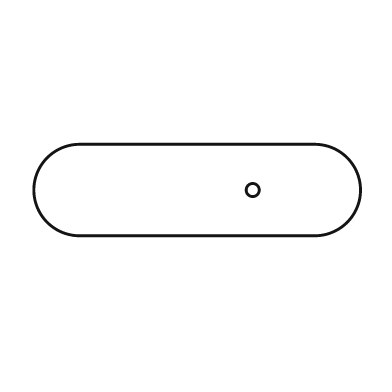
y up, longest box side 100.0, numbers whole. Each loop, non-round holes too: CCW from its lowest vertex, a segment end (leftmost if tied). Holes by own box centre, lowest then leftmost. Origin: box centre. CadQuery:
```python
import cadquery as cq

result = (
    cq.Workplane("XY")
    .moveTo(-36.0, -14.0)
    .lineTo(36.0, -14.0)
    .threePointArc((50.0, 0.0), (36.0, 14.0))
    .lineTo(-36.0, 14.0)
    .threePointArc((-50.0, 0.0), (-36.0, -14.0))
    .close()
    .moveTo(17.0, 0.0)
    .circle(2.0)
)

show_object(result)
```